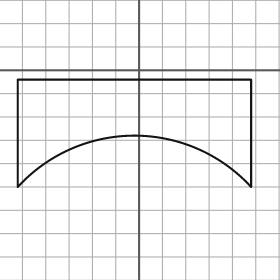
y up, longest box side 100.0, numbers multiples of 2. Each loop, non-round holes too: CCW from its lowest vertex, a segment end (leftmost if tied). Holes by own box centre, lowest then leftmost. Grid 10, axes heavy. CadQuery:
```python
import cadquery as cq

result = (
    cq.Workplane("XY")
    .moveTo(-52.0, -50.0)
    .threePointArc((-2.0, -28.0), (48.0, -50.0))
    .lineTo(48.0, -4.0)
    .lineTo(-52.0, -4.0)
    .close()
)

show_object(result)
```